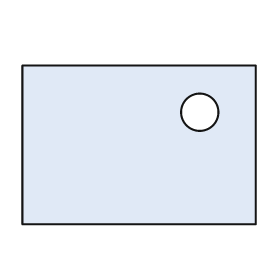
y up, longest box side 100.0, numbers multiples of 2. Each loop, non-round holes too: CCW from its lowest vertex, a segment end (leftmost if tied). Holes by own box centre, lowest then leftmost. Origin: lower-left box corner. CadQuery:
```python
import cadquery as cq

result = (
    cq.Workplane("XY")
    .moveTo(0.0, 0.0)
    .lineTo(100.0, 0.0)
    .lineTo(100.0, 68.0)
    .lineTo(0.0, 68.0)
    .close()
    .moveTo(76.0, 48.0)
    .circle(8.0)
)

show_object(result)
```